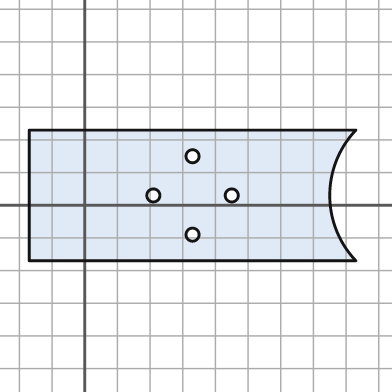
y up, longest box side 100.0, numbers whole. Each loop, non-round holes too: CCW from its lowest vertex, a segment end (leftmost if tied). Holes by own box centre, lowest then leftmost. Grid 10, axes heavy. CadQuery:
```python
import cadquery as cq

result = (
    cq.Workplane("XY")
    .moveTo(-17.0, -17.0)
    .lineTo(83.0, -17.0)
    .threePointArc((75.0, 3.0), (83.0, 23.0))
    .lineTo(-17.0, 23.0)
    .close()
    .moveTo(33.0, -9.0)
    .circle(2.0)
    .moveTo(21.0, 3.0)
    .circle(2.0)
    .moveTo(45.0, 3.0)
    .circle(2.0)
    .moveTo(33.0, 15.0)
    .circle(2.0)
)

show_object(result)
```